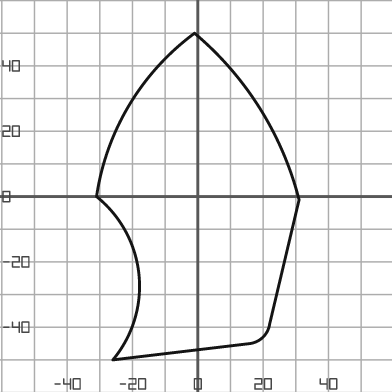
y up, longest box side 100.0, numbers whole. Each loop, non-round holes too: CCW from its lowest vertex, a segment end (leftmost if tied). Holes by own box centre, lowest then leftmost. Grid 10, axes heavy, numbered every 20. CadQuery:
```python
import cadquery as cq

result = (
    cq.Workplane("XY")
    .moveTo(-26.0, -50.0)
    .lineTo(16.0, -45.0)
    .threePointArc((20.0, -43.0), (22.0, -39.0))
    .lineTo(31.0, -1.0)
    .threePointArc((19.0, 27.0), (-1.0, 50.0))
    .threePointArc((-21.0, 28.0), (-31.0, 0.0))
    .threePointArc((-18.0, -24.0), (-26.0, -50.0))
    .close()
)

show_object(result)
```